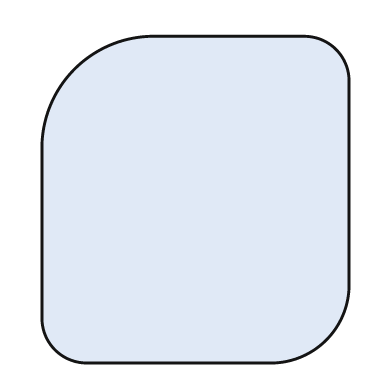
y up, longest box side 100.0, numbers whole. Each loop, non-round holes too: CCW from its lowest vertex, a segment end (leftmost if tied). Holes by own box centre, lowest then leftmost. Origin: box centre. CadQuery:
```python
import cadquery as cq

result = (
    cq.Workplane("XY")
    .moveTo(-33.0, -50.0)
    .lineTo(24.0, -50.0)
    .threePointArc((40.0, -43.0), (47.0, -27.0))
    .lineTo(47.0, 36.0)
    .threePointArc((43.0, 46.0), (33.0, 50.0))
    .lineTo(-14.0, 50.0)
    .threePointArc((-37.0, 40.0), (-47.0, 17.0))
    .lineTo(-47.0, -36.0)
    .threePointArc((-43.0, -46.0), (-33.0, -50.0))
    .close()
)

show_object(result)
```